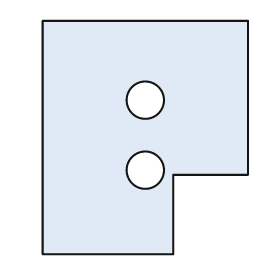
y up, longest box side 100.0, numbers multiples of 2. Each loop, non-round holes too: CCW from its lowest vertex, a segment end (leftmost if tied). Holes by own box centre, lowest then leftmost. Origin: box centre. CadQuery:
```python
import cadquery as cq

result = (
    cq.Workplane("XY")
    .moveTo(-44.0, -50.0)
    .lineTo(12.0, -50.0)
    .lineTo(12.0, -16.0)
    .lineTo(44.0, -16.0)
    .lineTo(44.0, 50.0)
    .lineTo(-44.0, 50.0)
    .close()
    .moveTo(0.0, -14.0)
    .circle(8.0)
    .moveTo(0.0, 16.0)
    .circle(8.0)
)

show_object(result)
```